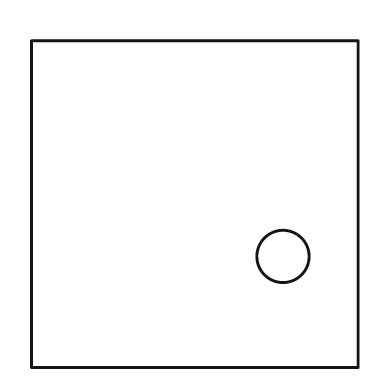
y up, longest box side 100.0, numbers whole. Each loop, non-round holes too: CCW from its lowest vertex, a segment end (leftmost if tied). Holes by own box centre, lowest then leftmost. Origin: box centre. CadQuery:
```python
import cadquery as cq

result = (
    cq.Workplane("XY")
    .moveTo(-50.0, -50.0)
    .lineTo(50.0, -50.0)
    .lineTo(50.0, 50.0)
    .lineTo(-50.0, 50.0)
    .close()
    .moveTo(27.0, -16.0)
    .circle(8.0)
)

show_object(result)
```